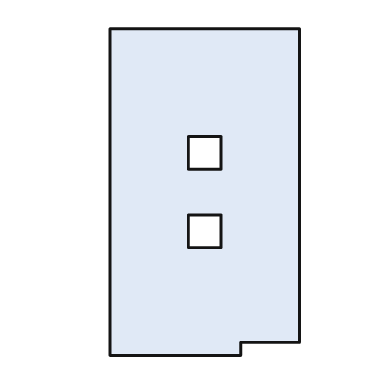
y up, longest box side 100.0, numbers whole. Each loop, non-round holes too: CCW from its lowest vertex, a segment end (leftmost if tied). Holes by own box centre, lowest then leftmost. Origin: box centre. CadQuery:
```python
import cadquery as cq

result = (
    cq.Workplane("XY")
    .moveTo(-29.0, -50.0)
    .lineTo(11.0, -50.0)
    .lineTo(11.0, -46.0)
    .lineTo(29.0, -46.0)
    .lineTo(29.0, 50.0)
    .lineTo(-29.0, 50.0)
    .close()
    .moveTo(-5.0, -17.0)
    .lineTo(5.0, -17.0)
    .lineTo(5.0, -7.0)
    .lineTo(-5.0, -7.0)
    .close()
    .moveTo(-5.0, 7.0)
    .lineTo(5.0, 7.0)
    .lineTo(5.0, 17.0)
    .lineTo(-5.0, 17.0)
    .close()
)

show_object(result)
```